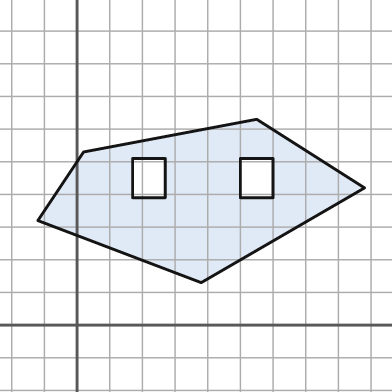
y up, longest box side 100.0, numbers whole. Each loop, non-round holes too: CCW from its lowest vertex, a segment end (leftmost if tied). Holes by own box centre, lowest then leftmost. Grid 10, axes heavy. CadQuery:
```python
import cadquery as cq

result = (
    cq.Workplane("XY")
    .moveTo(38.0, 13.0)
    .lineTo(88.0, 42.0)
    .lineTo(55.0, 63.0)
    .lineTo(2.0, 53.0)
    .lineTo(-12.0, 32.0)
    .close()
    .moveTo(17.0, 39.0)
    .lineTo(27.0, 39.0)
    .lineTo(27.0, 51.0)
    .lineTo(17.0, 51.0)
    .close()
    .moveTo(50.0, 39.0)
    .lineTo(60.0, 39.0)
    .lineTo(60.0, 51.0)
    .lineTo(50.0, 51.0)
    .close()
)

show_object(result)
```